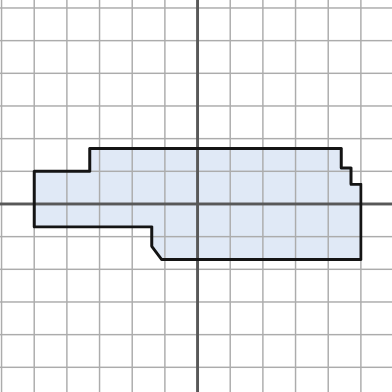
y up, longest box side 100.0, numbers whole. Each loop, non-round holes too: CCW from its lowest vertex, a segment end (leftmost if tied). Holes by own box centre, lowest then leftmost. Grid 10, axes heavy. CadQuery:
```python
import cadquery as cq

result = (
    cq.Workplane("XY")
    .moveTo(-11.0, -17.0)
    .lineTo(50.0, -17.0)
    .lineTo(50.0, 6.0)
    .lineTo(47.0, 6.0)
    .lineTo(47.0, 11.0)
    .lineTo(44.0, 11.0)
    .lineTo(44.0, 17.0)
    .lineTo(-33.0, 17.0)
    .lineTo(-33.0, 10.0)
    .lineTo(-50.0, 10.0)
    .lineTo(-50.0, -7.0)
    .lineTo(-14.0, -7.0)
    .lineTo(-14.0, -13.0)
    .close()
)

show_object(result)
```